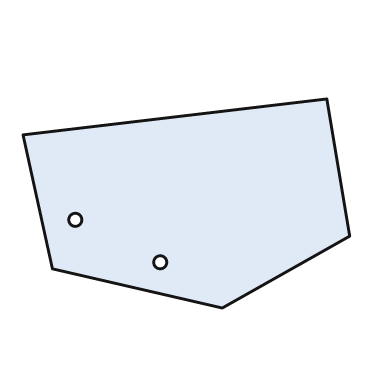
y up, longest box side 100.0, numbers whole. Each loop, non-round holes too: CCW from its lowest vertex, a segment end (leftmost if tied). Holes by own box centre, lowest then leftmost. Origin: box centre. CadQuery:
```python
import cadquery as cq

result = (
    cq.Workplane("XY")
    .moveTo(11.0, -32.0)
    .lineTo(50.0, -10.0)
    .lineTo(43.0, 32.0)
    .lineTo(-50.0, 21.0)
    .lineTo(-41.0, -20.0)
    .close()
    .moveTo(-8.0, -18.0)
    .circle(2.0)
    .moveTo(-34.0, -5.0)
    .circle(2.0)
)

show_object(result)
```